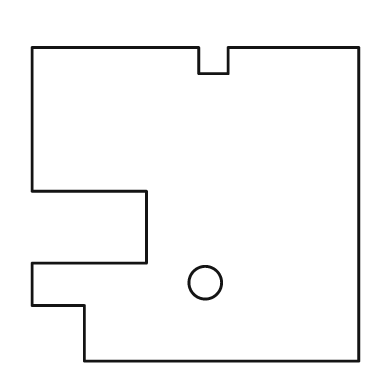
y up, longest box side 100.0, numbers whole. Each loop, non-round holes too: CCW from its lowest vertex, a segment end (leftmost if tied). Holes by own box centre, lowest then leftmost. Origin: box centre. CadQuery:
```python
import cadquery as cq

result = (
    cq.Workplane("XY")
    .moveTo(-34.0, -48.0)
    .lineTo(50.0, -48.0)
    .lineTo(50.0, 48.0)
    .lineTo(10.0, 48.0)
    .lineTo(10.0, 40.0)
    .lineTo(1.0, 40.0)
    .lineTo(1.0, 48.0)
    .lineTo(-50.0, 48.0)
    .lineTo(-50.0, 4.0)
    .lineTo(-15.0, 4.0)
    .lineTo(-15.0, -18.0)
    .lineTo(-50.0, -18.0)
    .lineTo(-50.0, -31.0)
    .lineTo(-34.0, -31.0)
    .close()
    .moveTo(3.0, -24.0)
    .circle(5.0)
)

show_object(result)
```